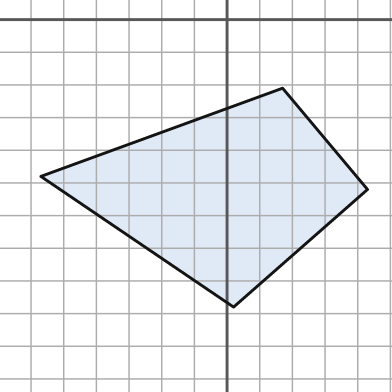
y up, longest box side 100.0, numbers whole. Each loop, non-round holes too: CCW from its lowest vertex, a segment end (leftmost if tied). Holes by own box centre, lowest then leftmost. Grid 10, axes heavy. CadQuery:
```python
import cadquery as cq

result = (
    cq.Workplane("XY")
    .moveTo(2.0, -88.0)
    .lineTo(43.0, -52.0)
    .lineTo(17.0, -21.0)
    .lineTo(-57.0, -48.0)
    .close()
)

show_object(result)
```